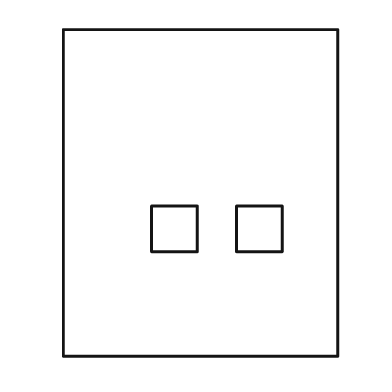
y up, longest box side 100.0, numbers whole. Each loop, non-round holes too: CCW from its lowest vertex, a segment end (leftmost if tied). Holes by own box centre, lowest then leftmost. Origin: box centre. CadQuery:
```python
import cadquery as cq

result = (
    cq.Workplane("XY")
    .moveTo(-42.0, -50.0)
    .lineTo(42.0, -50.0)
    .lineTo(42.0, 50.0)
    .lineTo(-42.0, 50.0)
    .close()
    .moveTo(-15.0, -18.0)
    .lineTo(-1.0, -18.0)
    .lineTo(-1.0, -4.0)
    .lineTo(-15.0, -4.0)
    .close()
    .moveTo(11.0, -18.0)
    .lineTo(25.0, -18.0)
    .lineTo(25.0, -4.0)
    .lineTo(11.0, -4.0)
    .close()
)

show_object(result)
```